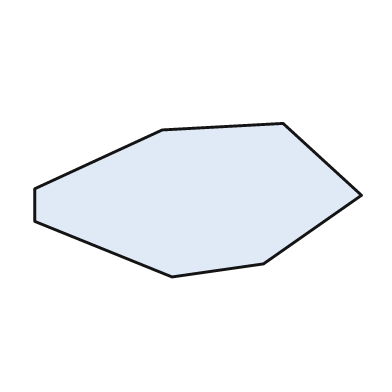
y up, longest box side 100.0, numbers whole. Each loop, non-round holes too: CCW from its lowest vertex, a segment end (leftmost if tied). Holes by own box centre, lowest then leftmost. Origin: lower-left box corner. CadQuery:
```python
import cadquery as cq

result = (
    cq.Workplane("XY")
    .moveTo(42.0, 0.0)
    .lineTo(70.0, 4.0)
    .lineTo(100.0, 25.0)
    .lineTo(76.0, 47.0)
    .lineTo(39.0, 45.0)
    .lineTo(0.0, 27.0)
    .lineTo(0.0, 17.0)
    .close()
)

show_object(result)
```